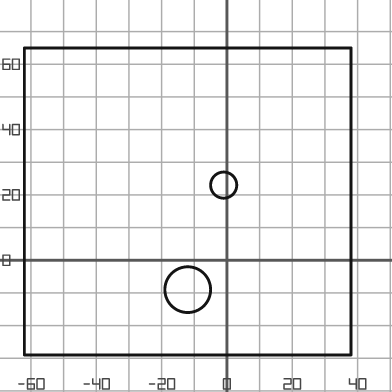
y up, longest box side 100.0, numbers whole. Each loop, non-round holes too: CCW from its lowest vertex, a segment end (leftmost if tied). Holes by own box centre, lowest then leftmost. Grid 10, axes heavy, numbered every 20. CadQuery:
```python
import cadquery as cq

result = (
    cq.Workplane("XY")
    .moveTo(-62.0, -29.0)
    .lineTo(38.0, -29.0)
    .lineTo(38.0, 65.0)
    .lineTo(-62.0, 65.0)
    .close()
    .moveTo(-12.0, -9.0)
    .circle(7.0)
    .moveTo(-1.0, 23.0)
    .circle(4.0)
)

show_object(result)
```